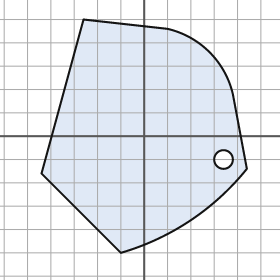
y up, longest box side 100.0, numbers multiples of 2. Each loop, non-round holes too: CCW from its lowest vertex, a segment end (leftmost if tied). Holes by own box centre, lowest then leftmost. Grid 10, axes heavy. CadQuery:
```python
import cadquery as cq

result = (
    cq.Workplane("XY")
    .moveTo(-10.0, -50.0)
    .threePointArc((20.0, -36.0), (44.0, -14.0))
    .lineTo(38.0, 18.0)
    .threePointArc((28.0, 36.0), (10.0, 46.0))
    .lineTo(-26.0, 50.0)
    .lineTo(-44.0, -16.0)
    .close()
    .moveTo(34.0, -10.0)
    .circle(4.0)
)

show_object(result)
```